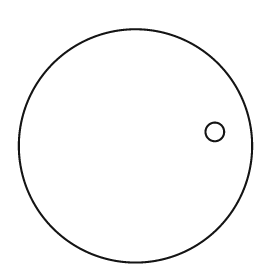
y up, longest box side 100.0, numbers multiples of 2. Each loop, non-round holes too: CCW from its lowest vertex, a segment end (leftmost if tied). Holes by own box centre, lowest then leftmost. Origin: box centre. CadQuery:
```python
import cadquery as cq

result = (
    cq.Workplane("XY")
    .moveTo(0.0, 0.0)
    .circle(50.0)
    .moveTo(34.0, 6.0)
    .circle(4.0)
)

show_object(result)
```